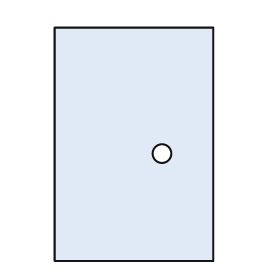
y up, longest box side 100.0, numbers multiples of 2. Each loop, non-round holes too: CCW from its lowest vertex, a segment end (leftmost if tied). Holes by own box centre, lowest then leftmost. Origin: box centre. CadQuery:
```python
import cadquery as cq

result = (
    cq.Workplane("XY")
    .moveTo(-34.0, -50.0)
    .lineTo(34.0, -50.0)
    .lineTo(34.0, 50.0)
    .lineTo(-34.0, 50.0)
    .close()
    .moveTo(12.0, -4.0)
    .circle(4.0)
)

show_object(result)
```